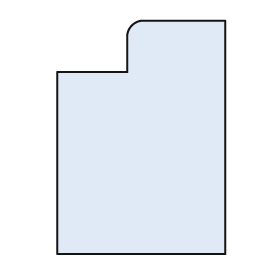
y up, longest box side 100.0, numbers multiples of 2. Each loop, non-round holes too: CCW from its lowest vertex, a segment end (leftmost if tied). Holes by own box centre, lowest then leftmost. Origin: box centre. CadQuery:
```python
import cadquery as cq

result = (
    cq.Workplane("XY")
    .moveTo(-36.0, -50.0)
    .lineTo(36.0, -50.0)
    .lineTo(36.0, 50.0)
    .lineTo(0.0, 50.0)
    .threePointArc((-4.0, 48.0), (-6.0, 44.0))
    .lineTo(-6.0, 28.0)
    .lineTo(-36.0, 28.0)
    .close()
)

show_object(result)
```